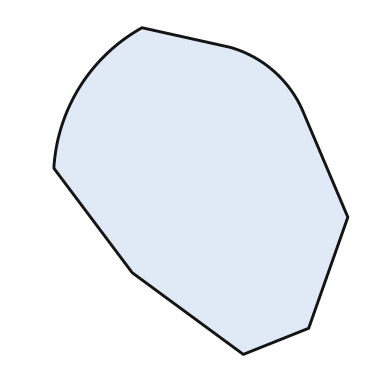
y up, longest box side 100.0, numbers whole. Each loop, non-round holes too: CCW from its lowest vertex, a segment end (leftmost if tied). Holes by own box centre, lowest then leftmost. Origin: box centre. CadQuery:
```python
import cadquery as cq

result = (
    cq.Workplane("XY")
    .moveTo(13.0, -50.0)
    .lineTo(33.0, -42.0)
    .lineTo(45.0, -8.0)
    .lineTo(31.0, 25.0)
    .threePointArc((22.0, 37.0), (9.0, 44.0))
    .lineTo(-18.0, 50.0)
    .threePointArc((-37.0, 32.0), (-45.0, 7.0))
    .lineTo(-21.0, -25.0)
    .close()
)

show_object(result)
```